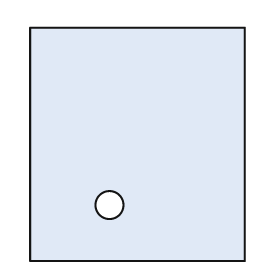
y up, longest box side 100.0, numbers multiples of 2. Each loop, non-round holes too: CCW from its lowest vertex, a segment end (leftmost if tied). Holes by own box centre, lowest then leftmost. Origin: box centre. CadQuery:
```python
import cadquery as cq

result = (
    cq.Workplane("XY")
    .moveTo(-46.0, -50.0)
    .lineTo(46.0, -50.0)
    .lineTo(46.0, 50.0)
    .lineTo(-46.0, 50.0)
    .close()
    .moveTo(-12.0, -26.0)
    .circle(6.0)
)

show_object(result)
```